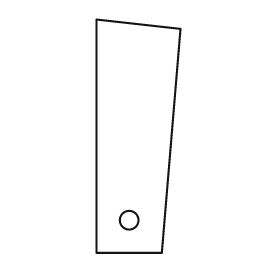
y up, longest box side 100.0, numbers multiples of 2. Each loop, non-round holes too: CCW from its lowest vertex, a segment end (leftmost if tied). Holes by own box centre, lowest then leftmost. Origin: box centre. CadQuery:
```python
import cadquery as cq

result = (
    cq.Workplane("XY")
    .moveTo(-18.0, -50.0)
    .lineTo(10.0, -50.0)
    .lineTo(18.0, 46.0)
    .lineTo(-18.0, 50.0)
    .close()
    .moveTo(-4.0, -36.0)
    .circle(4.0)
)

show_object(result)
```